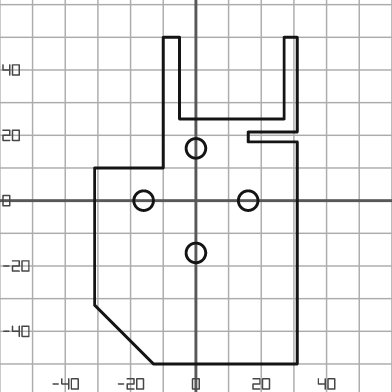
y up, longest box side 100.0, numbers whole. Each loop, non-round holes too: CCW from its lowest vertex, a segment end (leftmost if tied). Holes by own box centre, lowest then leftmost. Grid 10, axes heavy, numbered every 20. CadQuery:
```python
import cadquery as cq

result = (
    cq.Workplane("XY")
    .moveTo(-13.0, -50.0)
    .lineTo(31.0, -50.0)
    .lineTo(31.0, 18.0)
    .lineTo(16.0, 18.0)
    .lineTo(16.0, 21.0)
    .lineTo(31.0, 21.0)
    .lineTo(31.0, 50.0)
    .lineTo(27.0, 50.0)
    .lineTo(27.0, 25.0)
    .lineTo(-5.0, 25.0)
    .lineTo(-5.0, 50.0)
    .lineTo(-10.0, 50.0)
    .lineTo(-10.0, 10.0)
    .lineTo(-31.0, 10.0)
    .lineTo(-31.0, -32.0)
    .close()
    .moveTo(0.0, -16.0)
    .circle(3.0)
    .moveTo(-16.0, 0.0)
    .circle(3.0)
    .moveTo(16.0, 0.0)
    .circle(3.0)
    .moveTo(0.0, 16.0)
    .circle(3.0)
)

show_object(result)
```